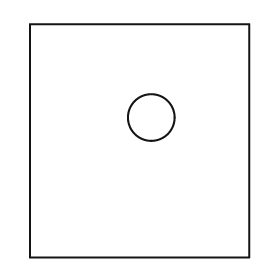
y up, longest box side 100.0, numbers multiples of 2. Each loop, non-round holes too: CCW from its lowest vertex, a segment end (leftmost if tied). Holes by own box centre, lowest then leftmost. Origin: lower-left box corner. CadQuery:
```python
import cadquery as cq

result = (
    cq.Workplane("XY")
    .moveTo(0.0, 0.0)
    .lineTo(94.0, 0.0)
    .lineTo(94.0, 100.0)
    .lineTo(0.0, 100.0)
    .close()
    .moveTo(52.0, 60.0)
    .circle(10.0)
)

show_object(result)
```